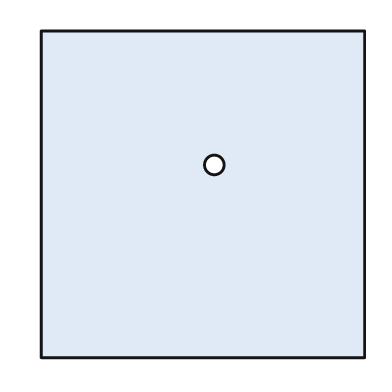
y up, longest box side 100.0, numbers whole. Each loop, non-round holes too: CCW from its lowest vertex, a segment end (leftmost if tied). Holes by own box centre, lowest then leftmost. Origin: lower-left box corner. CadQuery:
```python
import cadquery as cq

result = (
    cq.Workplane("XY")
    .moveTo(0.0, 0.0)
    .lineTo(99.0, 0.0)
    .lineTo(99.0, 100.0)
    .lineTo(0.0, 100.0)
    .close()
    .moveTo(53.0, 59.0)
    .circle(3.0)
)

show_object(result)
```